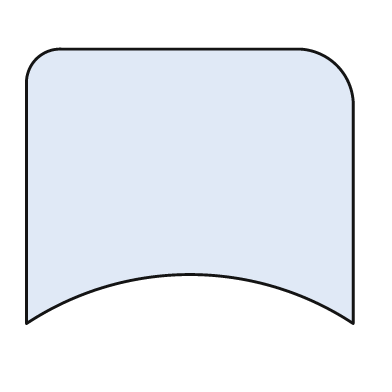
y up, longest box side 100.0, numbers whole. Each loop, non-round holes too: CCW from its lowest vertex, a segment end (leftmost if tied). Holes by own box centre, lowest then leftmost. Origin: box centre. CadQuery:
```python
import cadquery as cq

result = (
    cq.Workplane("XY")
    .moveTo(-50.0, -42.0)
    .threePointArc((0.0, -27.0), (50.0, -42.0))
    .lineTo(50.0, 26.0)
    .threePointArc((45.0, 37.0), (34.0, 42.0))
    .lineTo(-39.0, 42.0)
    .threePointArc((-47.0, 39.0), (-50.0, 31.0))
    .close()
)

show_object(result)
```